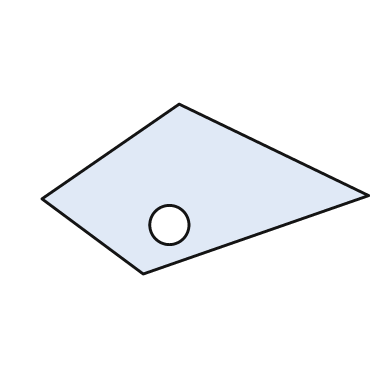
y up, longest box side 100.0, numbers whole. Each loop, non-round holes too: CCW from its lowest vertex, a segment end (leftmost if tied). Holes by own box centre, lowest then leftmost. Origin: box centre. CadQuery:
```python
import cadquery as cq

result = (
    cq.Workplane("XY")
    .moveTo(-19.0, -26.0)
    .lineTo(50.0, -2.0)
    .lineTo(-8.0, 26.0)
    .lineTo(-50.0, -3.0)
    .close()
    .moveTo(-11.0, -11.0)
    .circle(6.0)
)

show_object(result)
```